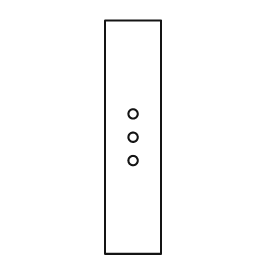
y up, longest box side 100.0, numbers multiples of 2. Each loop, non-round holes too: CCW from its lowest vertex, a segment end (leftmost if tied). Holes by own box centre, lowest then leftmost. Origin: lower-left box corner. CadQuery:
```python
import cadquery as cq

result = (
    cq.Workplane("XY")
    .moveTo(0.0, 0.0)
    .lineTo(24.0, 0.0)
    .lineTo(24.0, 100.0)
    .lineTo(0.0, 100.0)
    .close()
    .moveTo(12.0, 40.0)
    .circle(2.0)
    .moveTo(12.0, 50.0)
    .circle(2.0)
    .moveTo(12.0, 60.0)
    .circle(2.0)
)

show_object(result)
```